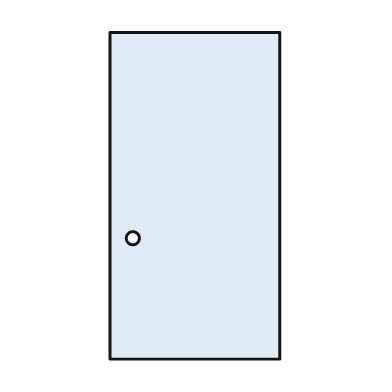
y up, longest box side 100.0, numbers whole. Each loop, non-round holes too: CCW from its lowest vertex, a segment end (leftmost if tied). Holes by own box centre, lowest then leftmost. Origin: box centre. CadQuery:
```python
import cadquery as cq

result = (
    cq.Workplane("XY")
    .moveTo(-26.0, -50.0)
    .lineTo(26.0, -50.0)
    .lineTo(26.0, 50.0)
    .lineTo(-26.0, 50.0)
    .close()
    .moveTo(-19.0, -13.0)
    .circle(2.0)
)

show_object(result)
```